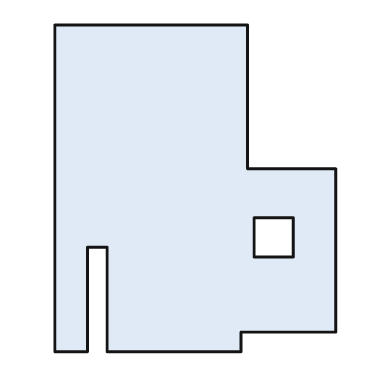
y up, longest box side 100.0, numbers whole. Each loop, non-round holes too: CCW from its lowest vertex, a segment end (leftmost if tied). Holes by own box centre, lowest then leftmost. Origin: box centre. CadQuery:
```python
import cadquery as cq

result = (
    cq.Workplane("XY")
    .moveTo(-43.0, -50.0)
    .lineTo(-33.0, -50.0)
    .lineTo(-33.0, -18.0)
    .lineTo(-27.0, -18.0)
    .lineTo(-27.0, -50.0)
    .lineTo(14.0, -50.0)
    .lineTo(14.0, -44.0)
    .lineTo(43.0, -44.0)
    .lineTo(43.0, 6.0)
    .lineTo(16.0, 6.0)
    .lineTo(16.0, 50.0)
    .lineTo(-43.0, 50.0)
    .close()
    .moveTo(18.0, -21.0)
    .lineTo(30.0, -21.0)
    .lineTo(30.0, -9.0)
    .lineTo(18.0, -9.0)
    .close()
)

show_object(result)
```